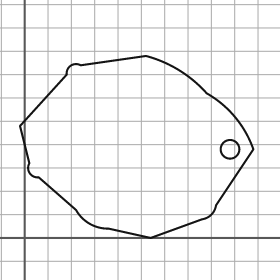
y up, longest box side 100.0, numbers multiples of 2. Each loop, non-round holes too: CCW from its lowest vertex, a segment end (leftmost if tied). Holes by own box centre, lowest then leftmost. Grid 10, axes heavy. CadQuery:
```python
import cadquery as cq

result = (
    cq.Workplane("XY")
    .moveTo(54.0, 0.0)
    .lineTo(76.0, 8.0)
    .threePointArc((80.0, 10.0), (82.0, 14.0))
    .lineTo(98.0, 38.0)
    .threePointArc((90.0, 52.0), (78.0, 62.0))
    .threePointArc((66.0, 72.0), (52.0, 78.0))
    .lineTo(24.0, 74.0)
    .threePointArc((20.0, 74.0), (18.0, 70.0))
    .lineTo(-2.0, 48.0)
    .lineTo(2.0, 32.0)
    .threePointArc((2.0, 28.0), (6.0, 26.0))
    .lineTo(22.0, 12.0)
    .threePointArc((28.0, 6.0), (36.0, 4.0))
    .close()
    .moveTo(88.0, 38.0)
    .circle(4.0)
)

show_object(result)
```